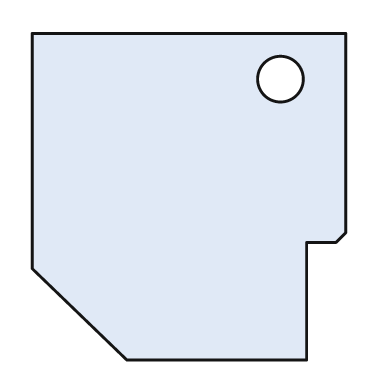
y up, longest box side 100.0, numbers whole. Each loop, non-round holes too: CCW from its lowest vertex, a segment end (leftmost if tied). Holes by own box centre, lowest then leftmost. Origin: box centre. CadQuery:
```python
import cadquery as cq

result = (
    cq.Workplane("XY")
    .moveTo(-19.0, -50.0)
    .lineTo(36.0, -50.0)
    .lineTo(36.0, -14.0)
    .lineTo(45.0, -14.0)
    .lineTo(48.0, -11.0)
    .lineTo(48.0, 50.0)
    .lineTo(-48.0, 50.0)
    .lineTo(-48.0, -22.0)
    .close()
    .moveTo(28.0, 36.0)
    .circle(7.0)
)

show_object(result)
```